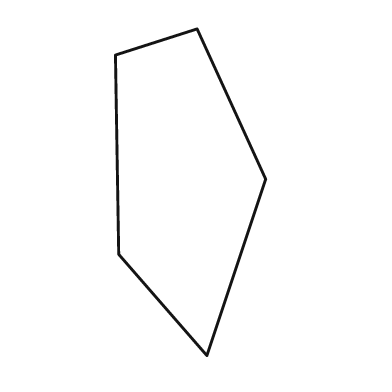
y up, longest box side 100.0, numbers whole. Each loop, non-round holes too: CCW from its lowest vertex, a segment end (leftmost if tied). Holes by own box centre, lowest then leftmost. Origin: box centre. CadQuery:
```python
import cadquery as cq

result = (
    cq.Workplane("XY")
    .moveTo(5.0, -50.0)
    .lineTo(23.0, 4.0)
    .lineTo(2.0, 50.0)
    .lineTo(-23.0, 42.0)
    .lineTo(-22.0, -19.0)
    .close()
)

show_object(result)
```